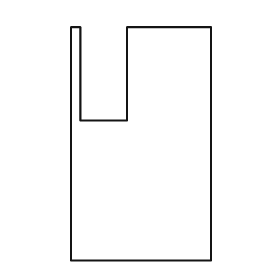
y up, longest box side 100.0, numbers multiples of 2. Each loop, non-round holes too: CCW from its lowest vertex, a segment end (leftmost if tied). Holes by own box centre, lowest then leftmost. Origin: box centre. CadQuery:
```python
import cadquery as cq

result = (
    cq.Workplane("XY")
    .moveTo(-30.0, -50.0)
    .lineTo(30.0, -50.0)
    .lineTo(30.0, 50.0)
    .lineTo(-6.0, 50.0)
    .lineTo(-6.0, 10.0)
    .lineTo(-26.0, 10.0)
    .lineTo(-26.0, 50.0)
    .lineTo(-30.0, 50.0)
    .close()
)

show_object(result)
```